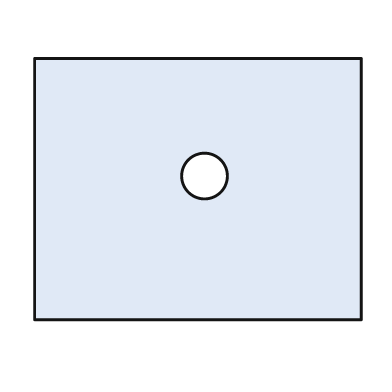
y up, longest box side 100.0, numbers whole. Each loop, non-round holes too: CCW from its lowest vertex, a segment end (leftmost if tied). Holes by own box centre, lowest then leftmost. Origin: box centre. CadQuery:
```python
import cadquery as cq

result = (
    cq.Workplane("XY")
    .moveTo(-50.0, -40.0)
    .lineTo(50.0, -40.0)
    .lineTo(50.0, 40.0)
    .lineTo(-50.0, 40.0)
    .close()
    .moveTo(2.0, 4.0)
    .circle(7.0)
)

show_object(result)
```